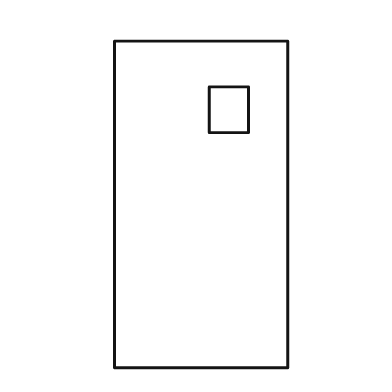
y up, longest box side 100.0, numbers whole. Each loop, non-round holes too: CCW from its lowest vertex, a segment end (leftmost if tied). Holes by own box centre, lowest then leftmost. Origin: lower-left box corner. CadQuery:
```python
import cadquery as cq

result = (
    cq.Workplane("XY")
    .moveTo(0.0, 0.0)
    .lineTo(53.0, 0.0)
    .lineTo(53.0, 100.0)
    .lineTo(0.0, 100.0)
    .close()
    .moveTo(29.0, 72.0)
    .lineTo(41.0, 72.0)
    .lineTo(41.0, 86.0)
    .lineTo(29.0, 86.0)
    .close()
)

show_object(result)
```